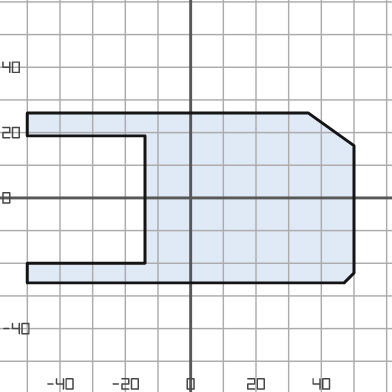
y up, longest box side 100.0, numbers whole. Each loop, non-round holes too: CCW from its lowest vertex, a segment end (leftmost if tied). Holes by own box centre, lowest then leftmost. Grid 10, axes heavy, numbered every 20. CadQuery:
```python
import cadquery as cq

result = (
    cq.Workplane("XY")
    .moveTo(-50.0, -26.0)
    .lineTo(47.0, -26.0)
    .lineTo(50.0, -23.0)
    .lineTo(50.0, 16.0)
    .lineTo(36.0, 26.0)
    .lineTo(-50.0, 26.0)
    .lineTo(-50.0, 19.0)
    .lineTo(-14.0, 19.0)
    .lineTo(-14.0, -20.0)
    .lineTo(-50.0, -20.0)
    .close()
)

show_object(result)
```